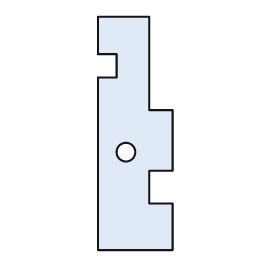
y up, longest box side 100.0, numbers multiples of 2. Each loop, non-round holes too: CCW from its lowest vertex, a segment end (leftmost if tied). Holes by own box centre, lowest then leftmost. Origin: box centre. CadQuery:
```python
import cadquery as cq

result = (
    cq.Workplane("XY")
    .moveTo(-16.0, -50.0)
    .lineTo(16.0, -50.0)
    .lineTo(16.0, -30.0)
    .lineTo(6.0, -30.0)
    .lineTo(6.0, -16.0)
    .lineTo(16.0, -16.0)
    .lineTo(16.0, 10.0)
    .lineTo(6.0, 10.0)
    .lineTo(6.0, 50.0)
    .lineTo(-16.0, 50.0)
    .lineTo(-16.0, 34.0)
    .lineTo(-8.0, 34.0)
    .lineTo(-8.0, 24.0)
    .lineTo(-16.0, 24.0)
    .close()
    .moveTo(-4.0, -8.0)
    .circle(4.0)
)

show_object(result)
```